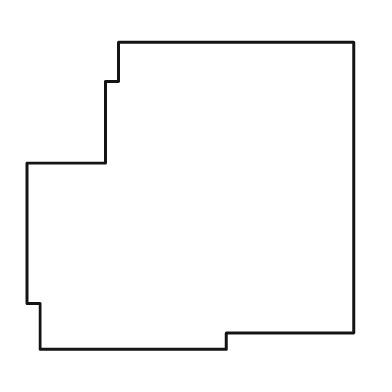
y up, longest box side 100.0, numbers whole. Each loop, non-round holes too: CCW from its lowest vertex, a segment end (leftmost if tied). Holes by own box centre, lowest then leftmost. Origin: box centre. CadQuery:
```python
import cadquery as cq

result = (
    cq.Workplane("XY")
    .moveTo(-46.0, -47.0)
    .lineTo(11.0, -47.0)
    .lineTo(11.0, -42.0)
    .lineTo(50.0, -42.0)
    .lineTo(50.0, 47.0)
    .lineTo(-22.0, 47.0)
    .lineTo(-22.0, 35.0)
    .lineTo(-26.0, 35.0)
    .lineTo(-26.0, 10.0)
    .lineTo(-50.0, 10.0)
    .lineTo(-50.0, -33.0)
    .lineTo(-46.0, -33.0)
    .close()
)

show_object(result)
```